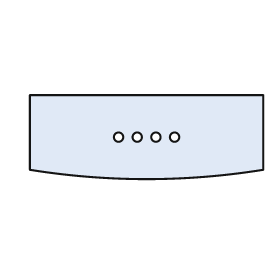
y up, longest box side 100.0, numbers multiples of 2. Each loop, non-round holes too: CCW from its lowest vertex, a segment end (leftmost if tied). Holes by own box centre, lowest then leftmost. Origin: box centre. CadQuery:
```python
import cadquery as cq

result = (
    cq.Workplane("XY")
    .moveTo(-50.0, -14.0)
    .threePointArc((0.0, -18.0), (50.0, -14.0))
    .lineTo(50.0, 18.0)
    .lineTo(-50.0, 18.0)
    .close()
    .moveTo(-12.0, 0.0)
    .circle(2.0)
    .moveTo(-4.0, 0.0)
    .circle(2.0)
    .moveTo(4.0, 0.0)
    .circle(2.0)
    .moveTo(12.0, 0.0)
    .circle(2.0)
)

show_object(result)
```